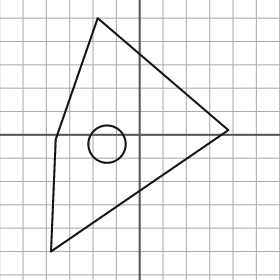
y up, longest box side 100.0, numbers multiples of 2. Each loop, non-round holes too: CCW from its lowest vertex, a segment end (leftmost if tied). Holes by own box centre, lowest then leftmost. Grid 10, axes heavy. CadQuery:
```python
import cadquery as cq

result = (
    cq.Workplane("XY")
    .moveTo(-38.0, -50.0)
    .lineTo(38.0, 2.0)
    .lineTo(-18.0, 50.0)
    .lineTo(-36.0, -2.0)
    .close()
    .moveTo(-14.0, -4.0)
    .circle(8.0)
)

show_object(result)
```